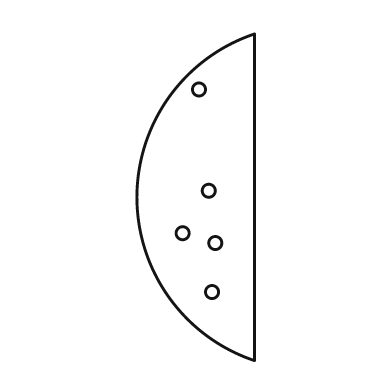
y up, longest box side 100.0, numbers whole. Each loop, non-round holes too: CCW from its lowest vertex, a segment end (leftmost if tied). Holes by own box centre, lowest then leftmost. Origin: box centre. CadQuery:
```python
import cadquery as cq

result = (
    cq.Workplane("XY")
    .moveTo(18.0, -50.0)
    .lineTo(18.0, 50.0)
    .threePointArc((-18.0, 0.0), (18.0, -50.0))
    .close()
    .moveTo(5.0, -29.0)
    .circle(2.0)
    .moveTo(6.0, -14.0)
    .circle(2.0)
    .moveTo(-4.0, -11.0)
    .circle(2.0)
    .moveTo(4.0, 2.0)
    .circle(2.0)
    .moveTo(1.0, 33.0)
    .circle(2.0)
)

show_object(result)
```